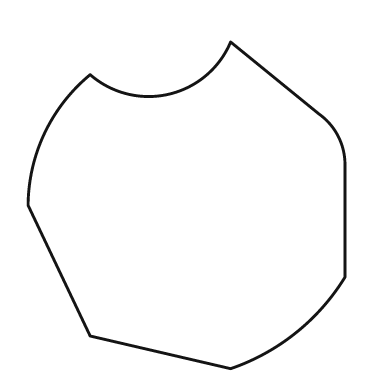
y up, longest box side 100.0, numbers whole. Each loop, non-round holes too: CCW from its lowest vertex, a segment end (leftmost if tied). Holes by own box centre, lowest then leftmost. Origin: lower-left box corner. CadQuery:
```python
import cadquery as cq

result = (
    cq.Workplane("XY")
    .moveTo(62.0, 0.0)
    .threePointArc((82.0, 11.0), (97.0, 28.0))
    .lineTo(97.0, 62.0)
    .threePointArc((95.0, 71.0), (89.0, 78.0))
    .lineTo(62.0, 100.0)
    .threePointArc((43.0, 84.0), (19.0, 90.0))
    .threePointArc((5.0, 72.0), (0.0, 50.0))
    .lineTo(19.0, 10.0)
    .close()
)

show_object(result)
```